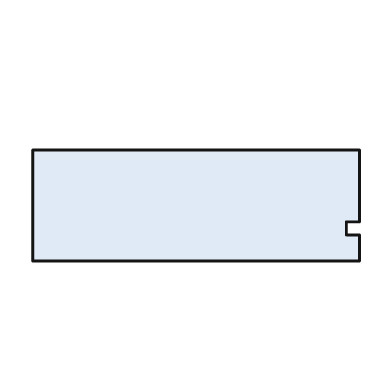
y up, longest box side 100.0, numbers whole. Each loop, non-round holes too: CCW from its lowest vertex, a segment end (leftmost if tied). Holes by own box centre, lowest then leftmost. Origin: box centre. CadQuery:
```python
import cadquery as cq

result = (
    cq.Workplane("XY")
    .moveTo(-50.0, -17.0)
    .lineTo(50.0, -17.0)
    .lineTo(50.0, -9.0)
    .lineTo(46.0, -9.0)
    .lineTo(46.0, -5.0)
    .lineTo(50.0, -5.0)
    .lineTo(50.0, 17.0)
    .lineTo(-50.0, 17.0)
    .close()
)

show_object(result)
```